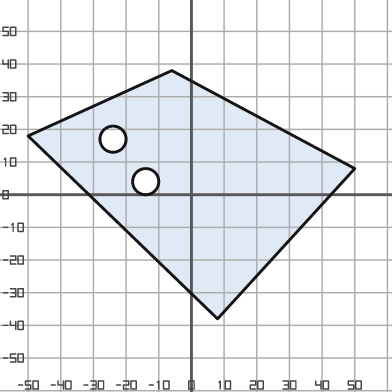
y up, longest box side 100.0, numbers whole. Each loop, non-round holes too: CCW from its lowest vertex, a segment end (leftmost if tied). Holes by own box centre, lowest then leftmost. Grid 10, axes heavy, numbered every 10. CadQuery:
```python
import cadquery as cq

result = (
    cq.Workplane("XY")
    .moveTo(8.0, -38.0)
    .lineTo(50.0, 8.0)
    .lineTo(-6.0, 38.0)
    .lineTo(-50.0, 18.0)
    .close()
    .moveTo(-14.0, 4.0)
    .circle(4.0)
    .moveTo(-24.0, 17.0)
    .circle(4.0)
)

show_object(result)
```